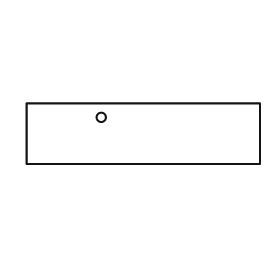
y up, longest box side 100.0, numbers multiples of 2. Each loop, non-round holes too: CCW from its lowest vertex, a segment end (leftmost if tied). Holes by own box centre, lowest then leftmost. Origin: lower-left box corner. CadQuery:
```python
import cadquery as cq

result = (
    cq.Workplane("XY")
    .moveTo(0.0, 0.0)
    .lineTo(100.0, 0.0)
    .lineTo(100.0, 26.0)
    .lineTo(0.0, 26.0)
    .close()
    .moveTo(32.0, 20.0)
    .circle(2.0)
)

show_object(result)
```